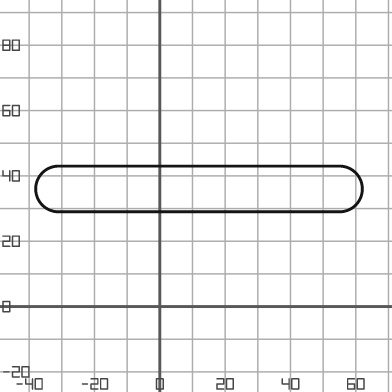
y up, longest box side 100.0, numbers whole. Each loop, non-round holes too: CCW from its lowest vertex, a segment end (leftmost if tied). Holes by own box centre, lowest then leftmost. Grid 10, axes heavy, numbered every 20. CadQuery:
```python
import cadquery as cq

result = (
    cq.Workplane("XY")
    .moveTo(-31.0, 29.0)
    .lineTo(55.0, 29.0)
    .threePointArc((62.0, 36.0), (55.0, 43.0))
    .lineTo(-31.0, 43.0)
    .threePointArc((-38.0, 36.0), (-31.0, 29.0))
    .close()
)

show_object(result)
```